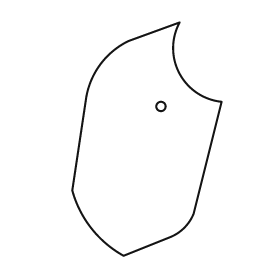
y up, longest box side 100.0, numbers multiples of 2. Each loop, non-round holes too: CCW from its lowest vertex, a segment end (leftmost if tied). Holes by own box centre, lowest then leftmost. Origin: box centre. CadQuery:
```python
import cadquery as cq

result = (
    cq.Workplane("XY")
    .moveTo(-10.0, -50.0)
    .lineTo(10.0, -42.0)
    .threePointArc((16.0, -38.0), (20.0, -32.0))
    .lineTo(32.0, 16.0)
    .threePointArc((14.0, 28.0), (14.0, 50.0))
    .lineTo(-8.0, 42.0)
    .threePointArc((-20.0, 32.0), (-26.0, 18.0))
    .lineTo(-32.0, -22.0)
    .threePointArc((-24.0, -38.0), (-10.0, -50.0))
    .close()
    .moveTo(6.0, 14.0)
    .circle(2.0)
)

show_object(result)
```